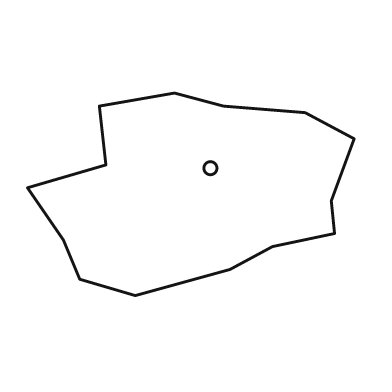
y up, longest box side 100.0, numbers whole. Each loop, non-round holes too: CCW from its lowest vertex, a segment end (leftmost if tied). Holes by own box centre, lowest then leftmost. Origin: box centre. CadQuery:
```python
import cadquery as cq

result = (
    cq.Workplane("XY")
    .moveTo(-17.0, -31.0)
    .lineTo(12.0, -23.0)
    .lineTo(25.0, -16.0)
    .lineTo(44.0, -12.0)
    .lineTo(43.0, -2.0)
    .lineTo(50.0, 17.0)
    .lineTo(35.0, 25.0)
    .lineTo(10.0, 27.0)
    .lineTo(-5.0, 31.0)
    .lineTo(-28.0, 27.0)
    .lineTo(-26.0, 9.0)
    .lineTo(-50.0, 2.0)
    .lineTo(-39.0, -14.0)
    .lineTo(-34.0, -26.0)
    .close()
    .moveTo(6.0, 8.0)
    .circle(2.0)
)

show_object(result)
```